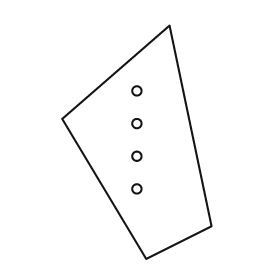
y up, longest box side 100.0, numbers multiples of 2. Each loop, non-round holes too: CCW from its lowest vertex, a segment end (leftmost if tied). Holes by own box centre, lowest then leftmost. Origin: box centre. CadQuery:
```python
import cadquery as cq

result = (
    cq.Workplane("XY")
    .moveTo(4.0, -50.0)
    .lineTo(32.0, -36.0)
    .lineTo(14.0, 50.0)
    .lineTo(-32.0, 10.0)
    .close()
    .moveTo(0.0, -20.0)
    .circle(2.0)
    .moveTo(0.0, -6.0)
    .circle(2.0)
    .moveTo(0.0, 8.0)
    .circle(2.0)
    .moveTo(0.0, 22.0)
    .circle(2.0)
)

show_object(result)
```